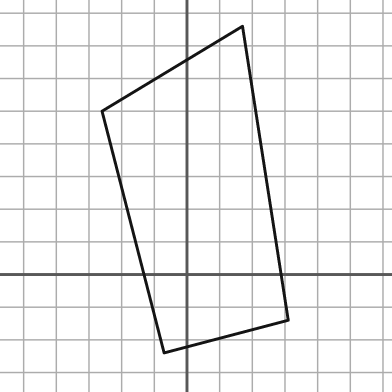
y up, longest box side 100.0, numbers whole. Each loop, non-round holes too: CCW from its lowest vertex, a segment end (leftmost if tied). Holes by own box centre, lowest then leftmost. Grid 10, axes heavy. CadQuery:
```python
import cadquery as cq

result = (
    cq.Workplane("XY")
    .moveTo(-7.0, -24.0)
    .lineTo(31.0, -14.0)
    .lineTo(17.0, 76.0)
    .lineTo(-26.0, 50.0)
    .close()
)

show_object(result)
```